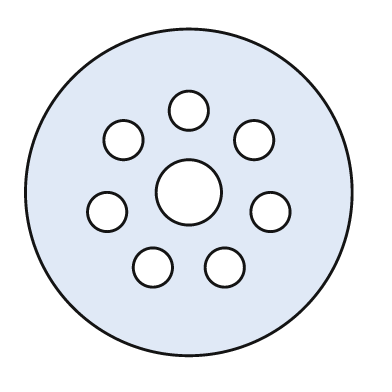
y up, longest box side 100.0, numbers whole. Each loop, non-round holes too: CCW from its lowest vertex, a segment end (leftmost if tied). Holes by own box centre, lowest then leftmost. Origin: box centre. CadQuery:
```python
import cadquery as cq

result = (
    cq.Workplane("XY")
    .moveTo(0.0, 0.0)
    .circle(50.0)
    .moveTo(-11.0, -23.0)
    .circle(6.0)
    .moveTo(11.0, -23.0)
    .circle(6.0)
    .moveTo(-25.0, -6.0)
    .circle(6.0)
    .moveTo(25.0, -6.0)
    .circle(6.0)
    .moveTo(0.0, 0.0)
    .circle(10.0)
    .moveTo(-20.0, 16.0)
    .circle(6.0)
    .moveTo(20.0, 16.0)
    .circle(6.0)
    .moveTo(0.0, 25.0)
    .circle(6.0)
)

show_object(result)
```